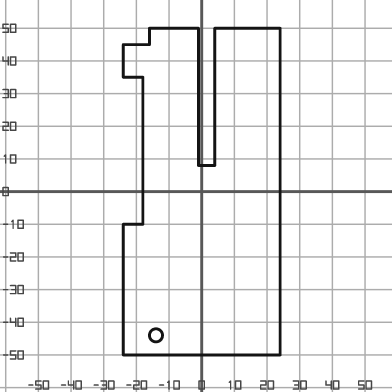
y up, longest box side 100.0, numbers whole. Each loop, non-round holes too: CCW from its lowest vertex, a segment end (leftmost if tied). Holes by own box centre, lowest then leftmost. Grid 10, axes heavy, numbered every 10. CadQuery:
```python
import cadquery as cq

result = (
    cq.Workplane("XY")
    .moveTo(-24.0, -50.0)
    .lineTo(24.0, -50.0)
    .lineTo(24.0, 50.0)
    .lineTo(4.0, 50.0)
    .lineTo(4.0, 8.0)
    .lineTo(-1.0, 8.0)
    .lineTo(-1.0, 50.0)
    .lineTo(-16.0, 50.0)
    .lineTo(-16.0, 45.0)
    .lineTo(-24.0, 45.0)
    .lineTo(-24.0, 35.0)
    .lineTo(-18.0, 35.0)
    .lineTo(-18.0, -10.0)
    .lineTo(-24.0, -10.0)
    .close()
    .moveTo(-14.0, -44.0)
    .circle(2.0)
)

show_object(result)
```